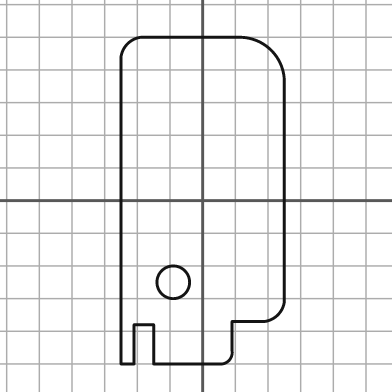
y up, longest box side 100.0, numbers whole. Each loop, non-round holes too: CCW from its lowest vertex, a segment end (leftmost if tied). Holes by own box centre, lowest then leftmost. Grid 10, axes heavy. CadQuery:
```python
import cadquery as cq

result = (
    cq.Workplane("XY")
    .moveTo(-25.0, -50.0)
    .lineTo(-21.0, -50.0)
    .lineTo(-21.0, -38.0)
    .lineTo(-15.0, -38.0)
    .lineTo(-15.0, -50.0)
    .lineTo(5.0, -50.0)
    .threePointArc((8.0, -49.0), (9.0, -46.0))
    .lineTo(9.0, -37.0)
    .lineTo(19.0, -37.0)
    .threePointArc((23.0, -35.0), (25.0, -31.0))
    .lineTo(25.0, 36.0)
    .threePointArc((21.0, 46.0), (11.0, 50.0))
    .lineTo(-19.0, 50.0)
    .threePointArc((-23.0, 48.0), (-25.0, 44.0))
    .close()
    .moveTo(-9.0, -25.0)
    .circle(5.0)
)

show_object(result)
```